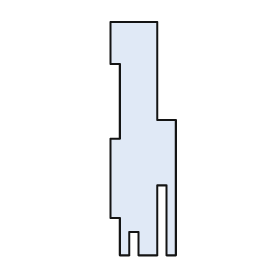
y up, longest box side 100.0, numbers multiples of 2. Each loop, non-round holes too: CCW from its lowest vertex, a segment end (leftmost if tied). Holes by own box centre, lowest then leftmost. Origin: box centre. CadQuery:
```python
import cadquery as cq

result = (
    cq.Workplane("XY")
    .moveTo(-10.0, -50.0)
    .lineTo(-6.0, -50.0)
    .lineTo(-6.0, -40.0)
    .lineTo(-2.0, -40.0)
    .lineTo(-2.0, -50.0)
    .lineTo(6.0, -50.0)
    .lineTo(6.0, -20.0)
    .lineTo(10.0, -20.0)
    .lineTo(10.0, -50.0)
    .lineTo(14.0, -50.0)
    .lineTo(14.0, 8.0)
    .lineTo(6.0, 8.0)
    .lineTo(6.0, 50.0)
    .lineTo(-14.0, 50.0)
    .lineTo(-14.0, 32.0)
    .lineTo(-10.0, 32.0)
    .lineTo(-10.0, 0.0)
    .lineTo(-14.0, 0.0)
    .lineTo(-14.0, -34.0)
    .lineTo(-10.0, -34.0)
    .close()
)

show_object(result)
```